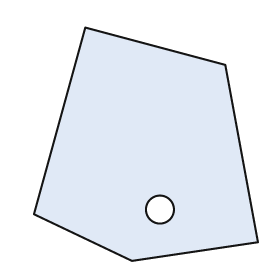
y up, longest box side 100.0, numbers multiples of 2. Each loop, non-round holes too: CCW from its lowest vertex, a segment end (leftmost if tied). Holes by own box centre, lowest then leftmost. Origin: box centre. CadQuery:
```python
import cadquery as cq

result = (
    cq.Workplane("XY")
    .moveTo(-6.0, -50.0)
    .lineTo(48.0, -42.0)
    .lineTo(34.0, 34.0)
    .lineTo(-26.0, 50.0)
    .lineTo(-48.0, -30.0)
    .close()
    .moveTo(6.0, -28.0)
    .circle(6.0)
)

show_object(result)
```